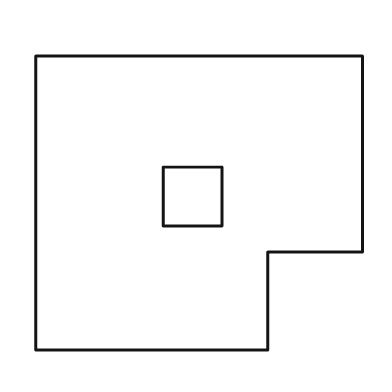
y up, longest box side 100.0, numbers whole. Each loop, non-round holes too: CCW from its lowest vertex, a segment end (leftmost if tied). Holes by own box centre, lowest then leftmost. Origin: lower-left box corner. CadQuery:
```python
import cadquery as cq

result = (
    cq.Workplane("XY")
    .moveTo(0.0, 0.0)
    .lineTo(71.0, 0.0)
    .lineTo(71.0, 30.0)
    .lineTo(100.0, 30.0)
    .lineTo(100.0, 90.0)
    .lineTo(0.0, 90.0)
    .close()
    .moveTo(39.0, 38.0)
    .lineTo(57.0, 38.0)
    .lineTo(57.0, 56.0)
    .lineTo(39.0, 56.0)
    .close()
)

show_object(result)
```